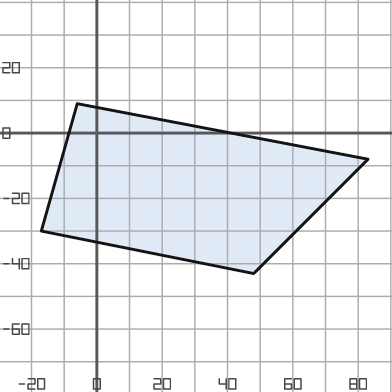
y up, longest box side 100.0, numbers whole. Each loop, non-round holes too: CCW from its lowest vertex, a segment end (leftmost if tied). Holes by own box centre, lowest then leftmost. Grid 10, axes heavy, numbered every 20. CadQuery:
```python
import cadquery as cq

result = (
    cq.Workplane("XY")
    .moveTo(48.0, -43.0)
    .lineTo(83.0, -8.0)
    .lineTo(-6.0, 9.0)
    .lineTo(-17.0, -30.0)
    .close()
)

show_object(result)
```